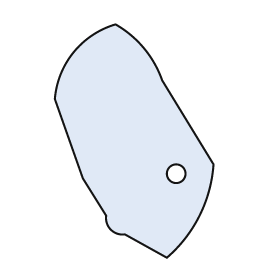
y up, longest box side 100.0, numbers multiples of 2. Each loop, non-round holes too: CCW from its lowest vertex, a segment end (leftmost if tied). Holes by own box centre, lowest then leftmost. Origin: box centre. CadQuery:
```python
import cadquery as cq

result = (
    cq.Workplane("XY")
    .moveTo(14.0, -50.0)
    .threePointArc((28.0, -32.0), (34.0, -10.0))
    .lineTo(12.0, 26.0)
    .threePointArc((4.0, 40.0), (-8.0, 50.0))
    .threePointArc((-26.0, 38.0), (-34.0, 18.0))
    .lineTo(-22.0, -16.0)
    .lineTo(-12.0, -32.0)
    .threePointArc((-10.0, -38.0), (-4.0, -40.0))
    .close()
    .moveTo(18.0, -14.0)
    .circle(4.0)
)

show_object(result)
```